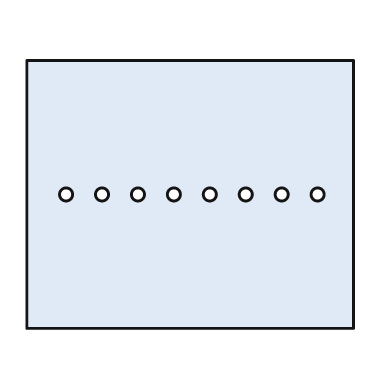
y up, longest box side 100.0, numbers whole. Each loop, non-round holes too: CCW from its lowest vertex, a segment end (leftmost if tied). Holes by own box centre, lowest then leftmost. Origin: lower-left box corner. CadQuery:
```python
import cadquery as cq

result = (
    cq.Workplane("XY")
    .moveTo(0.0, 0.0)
    .lineTo(100.0, 0.0)
    .lineTo(100.0, 82.0)
    .lineTo(0.0, 82.0)
    .close()
    .moveTo(12.0, 41.0)
    .circle(2.0)
    .moveTo(23.0, 41.0)
    .circle(2.0)
    .moveTo(34.0, 41.0)
    .circle(2.0)
    .moveTo(45.0, 41.0)
    .circle(2.0)
    .moveTo(56.0, 41.0)
    .circle(2.0)
    .moveTo(67.0, 41.0)
    .circle(2.0)
    .moveTo(78.0, 41.0)
    .circle(2.0)
    .moveTo(89.0, 41.0)
    .circle(2.0)
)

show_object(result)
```